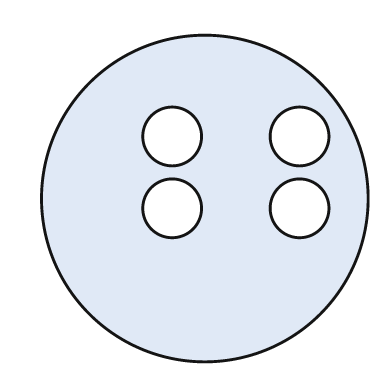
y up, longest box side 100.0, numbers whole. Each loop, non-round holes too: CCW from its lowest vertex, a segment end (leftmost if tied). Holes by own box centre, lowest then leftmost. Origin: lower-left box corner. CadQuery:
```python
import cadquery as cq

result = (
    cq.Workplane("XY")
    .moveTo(50.0, 50.0)
    .circle(50.0)
    .moveTo(40.0, 47.0)
    .circle(9.0)
    .moveTo(79.0, 47.0)
    .circle(9.0)
    .moveTo(40.0, 69.0)
    .circle(9.0)
    .moveTo(79.0, 69.0)
    .circle(9.0)
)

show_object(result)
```